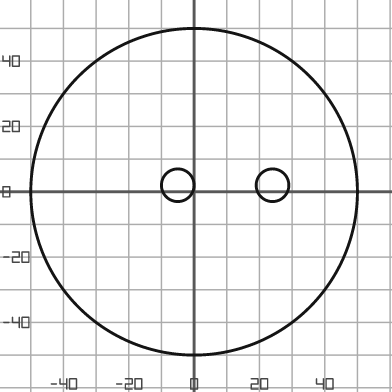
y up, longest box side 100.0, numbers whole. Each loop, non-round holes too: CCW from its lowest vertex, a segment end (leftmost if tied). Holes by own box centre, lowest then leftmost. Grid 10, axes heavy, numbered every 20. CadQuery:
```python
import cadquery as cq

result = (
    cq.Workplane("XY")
    .moveTo(0.0, 0.0)
    .circle(50.0)
    .moveTo(-5.0, 2.0)
    .circle(5.0)
    .moveTo(24.0, 2.0)
    .circle(5.0)
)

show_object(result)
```